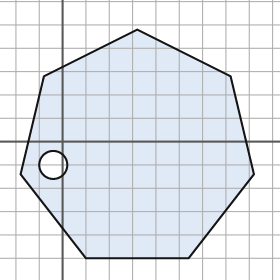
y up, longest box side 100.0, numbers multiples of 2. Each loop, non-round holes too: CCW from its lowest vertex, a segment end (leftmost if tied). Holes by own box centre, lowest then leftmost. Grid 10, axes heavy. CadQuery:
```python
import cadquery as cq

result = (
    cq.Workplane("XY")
    .moveTo(10.0, -50.0)
    .lineTo(54.0, -50.0)
    .lineTo(82.0, -14.0)
    .lineTo(72.0, 28.0)
    .lineTo(32.0, 48.0)
    .lineTo(-8.0, 28.0)
    .lineTo(-18.0, -14.0)
    .close()
    .moveTo(-4.0, -10.0)
    .circle(6.0)
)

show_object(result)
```